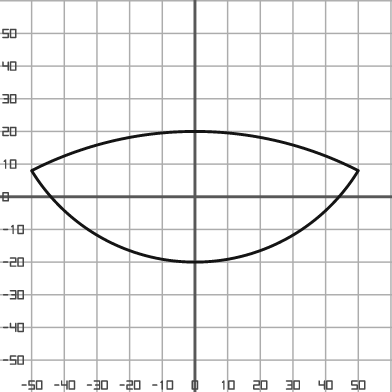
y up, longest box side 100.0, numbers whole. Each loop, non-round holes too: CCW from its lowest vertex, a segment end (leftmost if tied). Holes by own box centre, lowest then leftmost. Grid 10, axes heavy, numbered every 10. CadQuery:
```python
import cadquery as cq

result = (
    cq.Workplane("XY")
    .moveTo(-50.0, 8.0)
    .threePointArc((0.0, -20.0), (50.0, 8.0))
    .threePointArc((0.0, 20.0), (-50.0, 8.0))
    .close()
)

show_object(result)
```